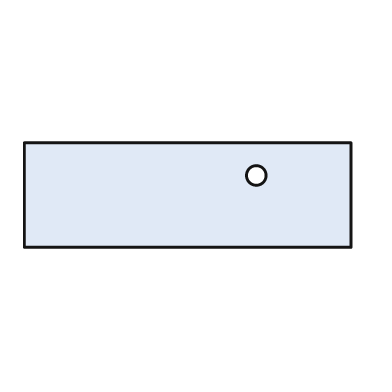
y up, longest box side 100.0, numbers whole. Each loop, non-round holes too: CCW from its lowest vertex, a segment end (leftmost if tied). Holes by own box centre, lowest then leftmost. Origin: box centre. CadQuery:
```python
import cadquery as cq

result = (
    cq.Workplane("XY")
    .moveTo(-50.0, -16.0)
    .lineTo(50.0, -16.0)
    .lineTo(50.0, 16.0)
    .lineTo(-50.0, 16.0)
    .close()
    .moveTo(21.0, 6.0)
    .circle(3.0)
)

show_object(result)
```